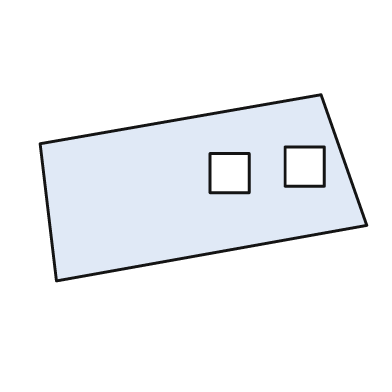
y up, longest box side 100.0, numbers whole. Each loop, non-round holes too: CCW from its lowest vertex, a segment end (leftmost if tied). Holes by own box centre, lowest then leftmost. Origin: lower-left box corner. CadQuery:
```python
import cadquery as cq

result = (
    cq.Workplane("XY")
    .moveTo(5.0, 0.0)
    .lineTo(100.0, 17.0)
    .lineTo(86.0, 57.0)
    .lineTo(0.0, 42.0)
    .close()
    .moveTo(52.0, 27.0)
    .lineTo(64.0, 27.0)
    .lineTo(64.0, 39.0)
    .lineTo(52.0, 39.0)
    .close()
    .moveTo(75.0, 29.0)
    .lineTo(87.0, 29.0)
    .lineTo(87.0, 41.0)
    .lineTo(75.0, 41.0)
    .close()
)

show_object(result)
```